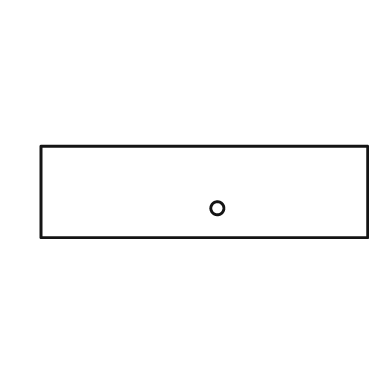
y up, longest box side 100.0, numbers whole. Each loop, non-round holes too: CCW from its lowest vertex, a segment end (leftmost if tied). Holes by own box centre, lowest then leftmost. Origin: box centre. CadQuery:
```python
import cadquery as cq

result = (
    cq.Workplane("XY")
    .moveTo(-50.0, -14.0)
    .lineTo(50.0, -14.0)
    .lineTo(50.0, 14.0)
    .lineTo(-50.0, 14.0)
    .close()
    .moveTo(4.0, -5.0)
    .circle(2.0)
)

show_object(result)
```